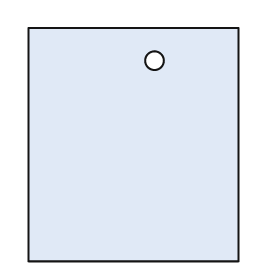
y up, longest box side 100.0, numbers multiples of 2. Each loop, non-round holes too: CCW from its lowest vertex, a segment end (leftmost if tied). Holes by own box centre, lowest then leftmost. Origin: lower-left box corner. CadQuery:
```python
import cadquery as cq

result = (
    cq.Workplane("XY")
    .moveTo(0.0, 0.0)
    .lineTo(90.0, 0.0)
    .lineTo(90.0, 100.0)
    .lineTo(0.0, 100.0)
    .close()
    .moveTo(54.0, 86.0)
    .circle(4.0)
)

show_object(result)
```